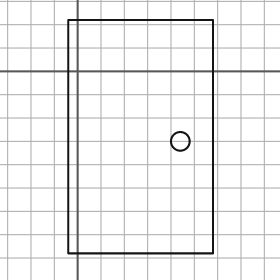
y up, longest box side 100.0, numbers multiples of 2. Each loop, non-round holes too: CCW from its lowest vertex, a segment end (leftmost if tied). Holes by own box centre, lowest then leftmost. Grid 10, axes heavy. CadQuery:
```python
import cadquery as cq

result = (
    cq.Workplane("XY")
    .moveTo(-4.0, -78.0)
    .lineTo(58.0, -78.0)
    .lineTo(58.0, 22.0)
    .lineTo(-4.0, 22.0)
    .close()
    .moveTo(44.0, -30.0)
    .circle(4.0)
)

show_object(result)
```